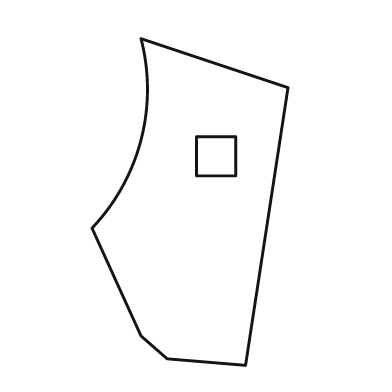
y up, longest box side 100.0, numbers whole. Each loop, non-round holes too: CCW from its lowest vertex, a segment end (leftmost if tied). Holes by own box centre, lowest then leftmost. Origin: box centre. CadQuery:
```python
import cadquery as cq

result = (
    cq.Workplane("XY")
    .moveTo(17.0, -50.0)
    .lineTo(30.0, 35.0)
    .lineTo(-15.0, 50.0)
    .threePointArc((-15.0, 19.0), (-30.0, -8.0))
    .lineTo(-15.0, -41.0)
    .lineTo(-7.0, -48.0)
    .close()
    .moveTo(2.0, 8.0)
    .lineTo(14.0, 8.0)
    .lineTo(14.0, 20.0)
    .lineTo(2.0, 20.0)
    .close()
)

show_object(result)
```